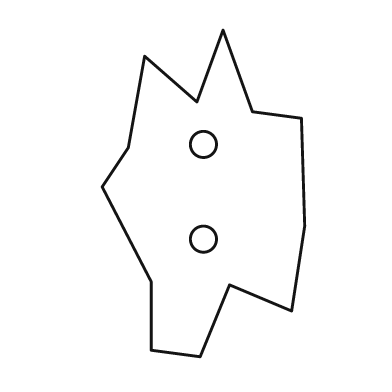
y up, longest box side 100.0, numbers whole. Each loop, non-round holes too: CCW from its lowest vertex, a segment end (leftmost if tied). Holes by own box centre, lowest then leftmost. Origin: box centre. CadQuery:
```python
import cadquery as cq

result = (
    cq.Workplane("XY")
    .moveTo(-1.0, -50.0)
    .lineTo(8.0, -28.0)
    .lineTo(27.0, -36.0)
    .lineTo(31.0, -10.0)
    .lineTo(30.0, 23.0)
    .lineTo(15.0, 25.0)
    .lineTo(6.0, 50.0)
    .lineTo(-2.0, 28.0)
    .lineTo(-18.0, 42.0)
    .lineTo(-23.0, 14.0)
    .lineTo(-31.0, 2.0)
    .lineTo(-16.0, -27.0)
    .lineTo(-16.0, -48.0)
    .close()
    .moveTo(0.0, -14.0)
    .circle(4.0)
    .moveTo(0.0, 15.0)
    .circle(4.0)
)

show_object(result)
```